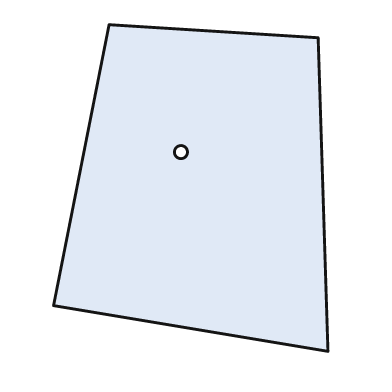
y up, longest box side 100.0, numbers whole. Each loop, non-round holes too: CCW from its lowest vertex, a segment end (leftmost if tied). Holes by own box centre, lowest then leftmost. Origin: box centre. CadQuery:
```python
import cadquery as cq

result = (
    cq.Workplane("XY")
    .moveTo(42.0, -50.0)
    .lineTo(39.0, 46.0)
    .lineTo(-25.0, 50.0)
    .lineTo(-42.0, -36.0)
    .close()
    .moveTo(-3.0, 11.0)
    .circle(2.0)
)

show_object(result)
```